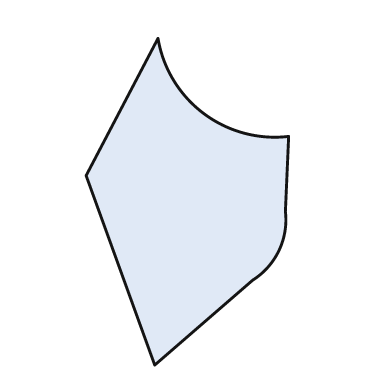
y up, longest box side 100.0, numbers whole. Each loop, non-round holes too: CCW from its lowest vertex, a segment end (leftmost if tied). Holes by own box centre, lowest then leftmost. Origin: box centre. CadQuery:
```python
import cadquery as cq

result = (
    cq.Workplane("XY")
    .moveTo(-10.0, -50.0)
    .lineTo(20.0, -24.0)
    .threePointArc((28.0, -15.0), (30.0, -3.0))
    .lineTo(31.0, 20.0)
    .threePointArc((5.0, 27.0), (-9.0, 50.0))
    .lineTo(-31.0, 8.0)
    .close()
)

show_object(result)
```